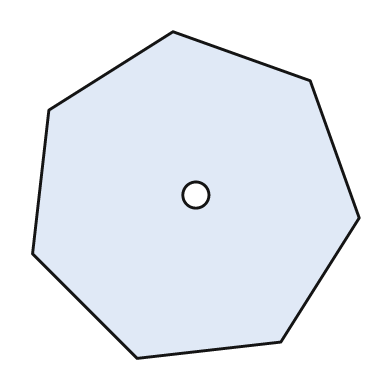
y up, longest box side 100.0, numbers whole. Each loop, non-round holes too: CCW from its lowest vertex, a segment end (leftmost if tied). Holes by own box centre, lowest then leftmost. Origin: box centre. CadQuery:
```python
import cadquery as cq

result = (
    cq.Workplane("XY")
    .moveTo(-18.0, -50.0)
    .lineTo(26.0, -45.0)
    .lineTo(50.0, -7.0)
    .lineTo(35.0, 35.0)
    .lineTo(-7.0, 50.0)
    .lineTo(-45.0, 26.0)
    .lineTo(-50.0, -18.0)
    .close()
    .moveTo(0.0, 0.0)
    .circle(4.0)
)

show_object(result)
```